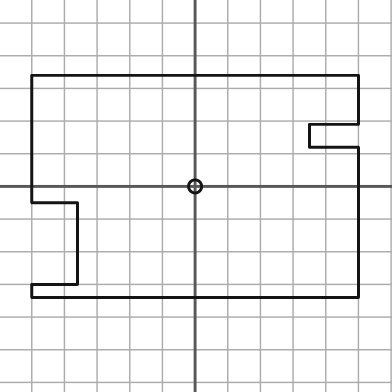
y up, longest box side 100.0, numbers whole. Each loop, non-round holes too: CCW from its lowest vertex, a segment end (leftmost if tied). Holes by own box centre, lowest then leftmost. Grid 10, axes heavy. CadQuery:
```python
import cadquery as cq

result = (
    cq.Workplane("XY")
    .moveTo(-50.0, -34.0)
    .lineTo(50.0, -34.0)
    .lineTo(50.0, 12.0)
    .lineTo(35.0, 12.0)
    .lineTo(35.0, 19.0)
    .lineTo(50.0, 19.0)
    .lineTo(50.0, 34.0)
    .lineTo(-50.0, 34.0)
    .lineTo(-50.0, -5.0)
    .lineTo(-36.0, -5.0)
    .lineTo(-36.0, -30.0)
    .lineTo(-50.0, -30.0)
    .close()
    .moveTo(0.0, 0.0)
    .circle(2.0)
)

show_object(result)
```